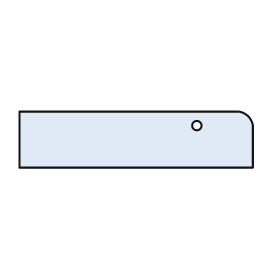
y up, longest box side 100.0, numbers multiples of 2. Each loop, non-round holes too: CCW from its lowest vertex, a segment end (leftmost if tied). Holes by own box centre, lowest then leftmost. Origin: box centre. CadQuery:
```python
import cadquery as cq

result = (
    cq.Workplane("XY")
    .moveTo(-50.0, -12.0)
    .lineTo(50.0, -12.0)
    .lineTo(50.0, 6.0)
    .threePointArc((48.0, 10.0), (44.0, 12.0))
    .lineTo(-50.0, 12.0)
    .close()
    .moveTo(26.0, 6.0)
    .circle(2.0)
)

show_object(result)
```